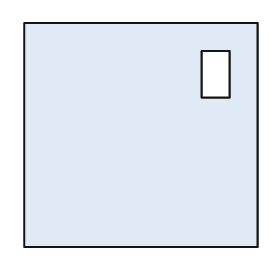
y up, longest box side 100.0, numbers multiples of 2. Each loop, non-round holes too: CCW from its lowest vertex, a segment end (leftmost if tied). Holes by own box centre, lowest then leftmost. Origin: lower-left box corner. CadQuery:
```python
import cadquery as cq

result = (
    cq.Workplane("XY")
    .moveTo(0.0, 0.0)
    .lineTo(100.0, 0.0)
    .lineTo(100.0, 96.0)
    .lineTo(0.0, 96.0)
    .close()
    .moveTo(76.0, 64.0)
    .lineTo(88.0, 64.0)
    .lineTo(88.0, 84.0)
    .lineTo(76.0, 84.0)
    .close()
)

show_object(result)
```